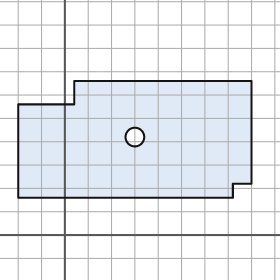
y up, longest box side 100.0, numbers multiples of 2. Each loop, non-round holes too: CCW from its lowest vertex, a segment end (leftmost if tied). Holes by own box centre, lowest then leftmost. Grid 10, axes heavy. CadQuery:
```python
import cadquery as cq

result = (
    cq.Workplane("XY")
    .moveTo(-20.0, 16.0)
    .lineTo(72.0, 16.0)
    .lineTo(72.0, 22.0)
    .lineTo(80.0, 22.0)
    .lineTo(80.0, 66.0)
    .lineTo(4.0, 66.0)
    .lineTo(4.0, 56.0)
    .lineTo(-20.0, 56.0)
    .close()
    .moveTo(30.0, 42.0)
    .circle(4.0)
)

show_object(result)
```